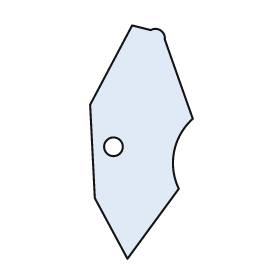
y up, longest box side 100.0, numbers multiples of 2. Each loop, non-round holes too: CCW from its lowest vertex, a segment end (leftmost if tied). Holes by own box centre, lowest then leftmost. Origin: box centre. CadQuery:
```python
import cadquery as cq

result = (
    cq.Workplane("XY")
    .moveTo(-6.0, -50.0)
    .lineTo(16.0, -20.0)
    .threePointArc((14.0, -4.0), (22.0, 10.0))
    .lineTo(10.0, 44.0)
    .threePointArc((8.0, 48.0), (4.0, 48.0))
    .lineTo(-4.0, 50.0)
    .lineTo(-22.0, 16.0)
    .lineTo(-20.0, -24.0)
    .close()
    .moveTo(-12.0, -2.0)
    .circle(4.0)
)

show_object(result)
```